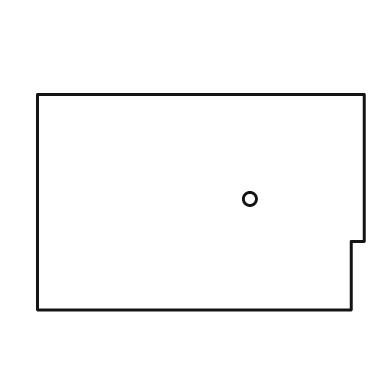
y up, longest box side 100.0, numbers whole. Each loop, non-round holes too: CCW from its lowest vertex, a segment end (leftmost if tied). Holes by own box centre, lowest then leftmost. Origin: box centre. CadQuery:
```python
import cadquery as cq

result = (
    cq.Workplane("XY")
    .moveTo(-50.0, -33.0)
    .lineTo(46.0, -33.0)
    .lineTo(46.0, -12.0)
    .lineTo(50.0, -12.0)
    .lineTo(50.0, 33.0)
    .lineTo(-50.0, 33.0)
    .close()
    .moveTo(15.0, 1.0)
    .circle(2.0)
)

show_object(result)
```